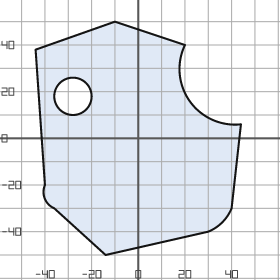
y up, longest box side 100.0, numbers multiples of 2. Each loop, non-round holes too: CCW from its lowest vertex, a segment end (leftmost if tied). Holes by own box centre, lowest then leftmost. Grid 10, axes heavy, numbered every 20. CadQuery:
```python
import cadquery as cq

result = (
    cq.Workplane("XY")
    .moveTo(-14.0, -50.0)
    .lineTo(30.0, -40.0)
    .threePointArc((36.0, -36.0), (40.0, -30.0))
    .lineTo(44.0, 6.0)
    .threePointArc((22.0, 16.0), (20.0, 40.0))
    .lineTo(-10.0, 50.0)
    .lineTo(-44.0, 38.0)
    .lineTo(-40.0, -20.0)
    .threePointArc((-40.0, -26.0), (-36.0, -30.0))
    .close()
    .moveTo(-28.0, 18.0)
    .circle(8.0)
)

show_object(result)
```